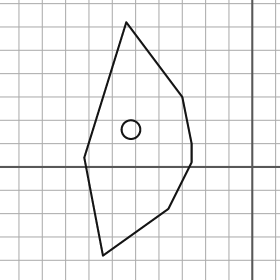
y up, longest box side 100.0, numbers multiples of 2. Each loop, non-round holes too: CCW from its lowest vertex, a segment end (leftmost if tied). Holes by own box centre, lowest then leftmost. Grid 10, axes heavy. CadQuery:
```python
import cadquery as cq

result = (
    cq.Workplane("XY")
    .moveTo(-64.0, -38.0)
    .lineTo(-36.0, -18.0)
    .lineTo(-26.0, 2.0)
    .lineTo(-26.0, 10.0)
    .lineTo(-30.0, 30.0)
    .lineTo(-54.0, 62.0)
    .lineTo(-72.0, 4.0)
    .close()
    .moveTo(-52.0, 16.0)
    .circle(4.0)
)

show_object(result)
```